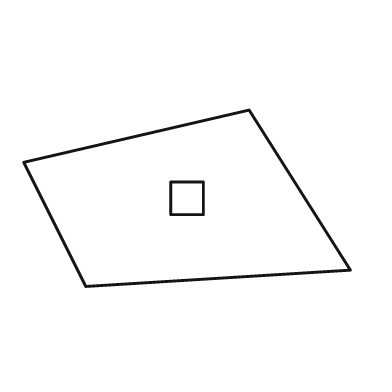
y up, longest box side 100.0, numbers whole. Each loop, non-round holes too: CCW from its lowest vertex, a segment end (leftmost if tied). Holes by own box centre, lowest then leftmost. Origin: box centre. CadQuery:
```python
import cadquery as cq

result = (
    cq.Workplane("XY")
    .moveTo(-31.0, -27.0)
    .lineTo(50.0, -22.0)
    .lineTo(19.0, 27.0)
    .lineTo(-50.0, 11.0)
    .close()
    .moveTo(-5.0, -5.0)
    .lineTo(5.0, -5.0)
    .lineTo(5.0, 5.0)
    .lineTo(-5.0, 5.0)
    .close()
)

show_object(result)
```